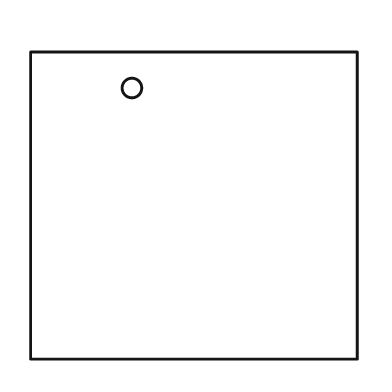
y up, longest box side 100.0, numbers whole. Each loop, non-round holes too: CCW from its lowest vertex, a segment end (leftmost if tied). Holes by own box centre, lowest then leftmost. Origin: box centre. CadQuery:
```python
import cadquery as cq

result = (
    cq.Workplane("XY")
    .moveTo(-50.0, -47.0)
    .lineTo(50.0, -47.0)
    .lineTo(50.0, 47.0)
    .lineTo(-50.0, 47.0)
    .close()
    .moveTo(-19.0, 36.0)
    .circle(3.0)
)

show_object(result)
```